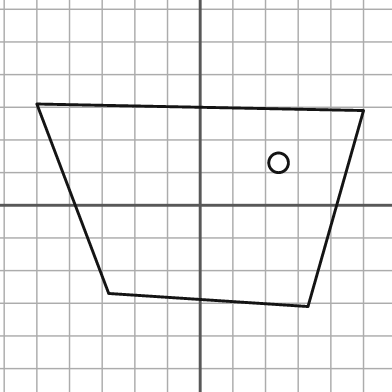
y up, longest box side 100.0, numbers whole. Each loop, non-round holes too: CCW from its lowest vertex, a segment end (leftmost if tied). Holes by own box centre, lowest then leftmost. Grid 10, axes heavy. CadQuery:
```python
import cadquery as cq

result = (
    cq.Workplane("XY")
    .moveTo(33.0, -31.0)
    .lineTo(50.0, 29.0)
    .lineTo(-50.0, 31.0)
    .lineTo(-28.0, -27.0)
    .close()
    .moveTo(24.0, 13.0)
    .circle(3.0)
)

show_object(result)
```